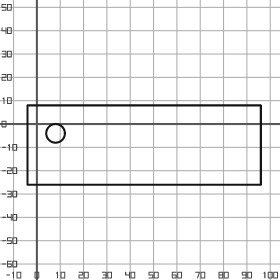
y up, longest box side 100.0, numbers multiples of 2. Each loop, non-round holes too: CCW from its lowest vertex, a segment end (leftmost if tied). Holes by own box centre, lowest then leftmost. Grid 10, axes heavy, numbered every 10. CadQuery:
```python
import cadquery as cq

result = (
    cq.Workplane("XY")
    .moveTo(-4.0, -26.0)
    .lineTo(96.0, -26.0)
    .lineTo(96.0, 8.0)
    .lineTo(-4.0, 8.0)
    .close()
    .moveTo(8.0, -4.0)
    .circle(4.0)
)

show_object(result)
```